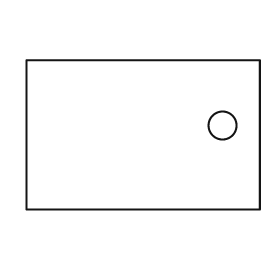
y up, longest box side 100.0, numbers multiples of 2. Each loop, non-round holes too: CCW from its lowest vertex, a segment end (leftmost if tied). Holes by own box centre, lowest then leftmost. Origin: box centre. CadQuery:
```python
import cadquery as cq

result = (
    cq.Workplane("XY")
    .moveTo(-50.0, -32.0)
    .lineTo(50.0, -32.0)
    .lineTo(50.0, 32.0)
    .lineTo(-50.0, 32.0)
    .close()
    .moveTo(34.0, 4.0)
    .circle(6.0)
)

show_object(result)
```